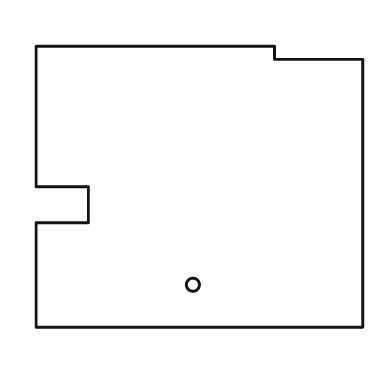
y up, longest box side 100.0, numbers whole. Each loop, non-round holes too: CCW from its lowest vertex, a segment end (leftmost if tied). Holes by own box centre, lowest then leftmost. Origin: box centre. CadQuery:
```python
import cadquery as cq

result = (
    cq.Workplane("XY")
    .moveTo(-50.0, -43.0)
    .lineTo(50.0, -43.0)
    .lineTo(50.0, 39.0)
    .lineTo(23.0, 39.0)
    .lineTo(23.0, 43.0)
    .lineTo(-50.0, 43.0)
    .lineTo(-50.0, 0.0)
    .lineTo(-34.0, 0.0)
    .lineTo(-34.0, -11.0)
    .lineTo(-50.0, -11.0)
    .close()
    .moveTo(-2.0, -30.0)
    .circle(2.0)
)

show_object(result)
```